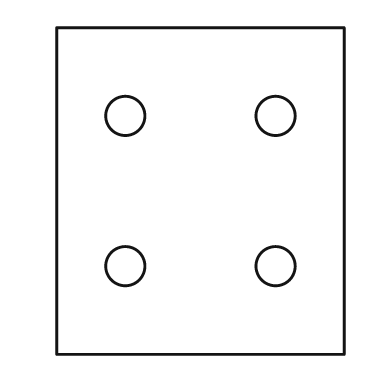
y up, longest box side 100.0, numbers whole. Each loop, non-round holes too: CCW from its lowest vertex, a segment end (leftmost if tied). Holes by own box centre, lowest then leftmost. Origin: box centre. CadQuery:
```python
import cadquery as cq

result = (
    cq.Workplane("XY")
    .moveTo(-44.0, -50.0)
    .lineTo(44.0, -50.0)
    .lineTo(44.0, 50.0)
    .lineTo(-44.0, 50.0)
    .close()
    .moveTo(-23.0, -23.0)
    .circle(6.0)
    .moveTo(23.0, -23.0)
    .circle(6.0)
    .moveTo(-23.0, 23.0)
    .circle(6.0)
    .moveTo(23.0, 23.0)
    .circle(6.0)
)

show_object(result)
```